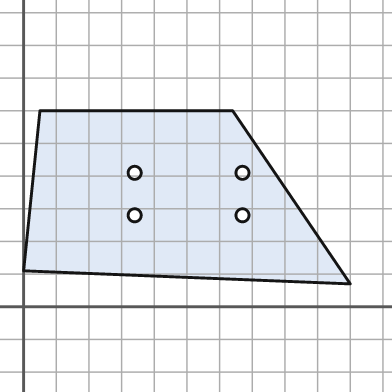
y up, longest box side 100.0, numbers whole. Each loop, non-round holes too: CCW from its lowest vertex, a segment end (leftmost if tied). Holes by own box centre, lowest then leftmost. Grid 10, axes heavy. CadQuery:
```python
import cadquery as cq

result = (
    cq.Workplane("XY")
    .moveTo(100.0, 7.0)
    .lineTo(64.0, 60.0)
    .lineTo(5.0, 60.0)
    .lineTo(0.0, 11.0)
    .close()
    .moveTo(34.0, 28.0)
    .circle(2.0)
    .moveTo(67.0, 28.0)
    .circle(2.0)
    .moveTo(34.0, 41.0)
    .circle(2.0)
    .moveTo(67.0, 41.0)
    .circle(2.0)
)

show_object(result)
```